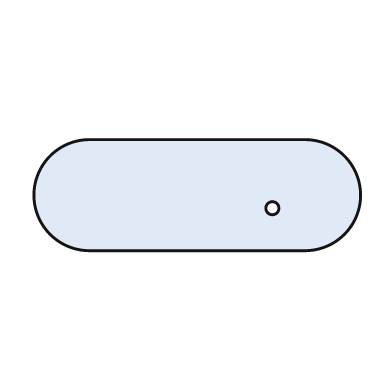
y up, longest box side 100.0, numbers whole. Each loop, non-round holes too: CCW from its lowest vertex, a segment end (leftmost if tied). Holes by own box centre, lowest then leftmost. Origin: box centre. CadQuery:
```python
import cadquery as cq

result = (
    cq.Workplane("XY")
    .moveTo(-33.0, -17.0)
    .lineTo(33.0, -17.0)
    .threePointArc((50.0, 0.0), (33.0, 17.0))
    .lineTo(-33.0, 17.0)
    .threePointArc((-50.0, 0.0), (-33.0, -17.0))
    .close()
    .moveTo(23.0, -4.0)
    .circle(2.0)
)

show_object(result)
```